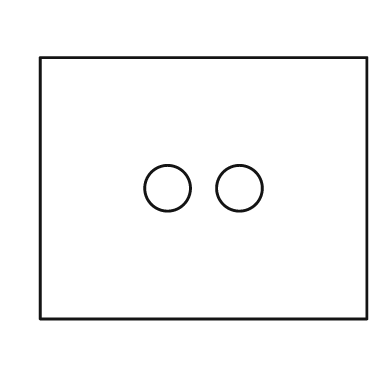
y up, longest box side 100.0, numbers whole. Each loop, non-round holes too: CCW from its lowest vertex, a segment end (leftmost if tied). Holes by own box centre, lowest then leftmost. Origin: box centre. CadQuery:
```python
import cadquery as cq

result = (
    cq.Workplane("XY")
    .moveTo(-50.0, -40.0)
    .lineTo(50.0, -40.0)
    .lineTo(50.0, 40.0)
    .lineTo(-50.0, 40.0)
    .close()
    .moveTo(-11.0, 0.0)
    .circle(7.0)
    .moveTo(11.0, 0.0)
    .circle(7.0)
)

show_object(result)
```